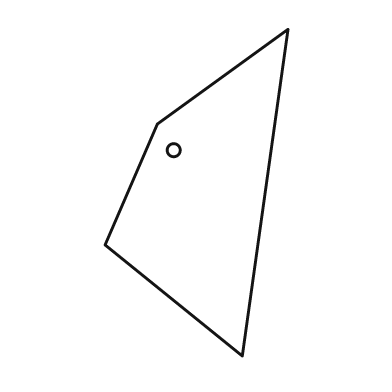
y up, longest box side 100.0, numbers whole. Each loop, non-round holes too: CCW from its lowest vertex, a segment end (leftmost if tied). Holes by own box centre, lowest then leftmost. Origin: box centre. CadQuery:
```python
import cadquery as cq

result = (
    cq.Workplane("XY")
    .moveTo(14.0, -50.0)
    .lineTo(28.0, 50.0)
    .lineTo(-12.0, 21.0)
    .lineTo(-28.0, -16.0)
    .close()
    .moveTo(-7.0, 13.0)
    .circle(2.0)
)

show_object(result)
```